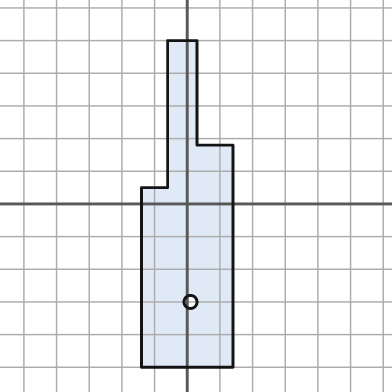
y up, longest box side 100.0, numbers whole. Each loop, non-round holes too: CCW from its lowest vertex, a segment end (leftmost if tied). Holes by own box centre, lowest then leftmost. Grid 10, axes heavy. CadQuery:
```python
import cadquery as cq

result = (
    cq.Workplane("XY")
    .moveTo(-14.0, -50.0)
    .lineTo(14.0, -50.0)
    .lineTo(14.0, 18.0)
    .lineTo(3.0, 18.0)
    .lineTo(3.0, 50.0)
    .lineTo(-6.0, 50.0)
    .lineTo(-6.0, 5.0)
    .lineTo(-14.0, 5.0)
    .close()
    .moveTo(1.0, -30.0)
    .circle(2.0)
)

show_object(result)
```